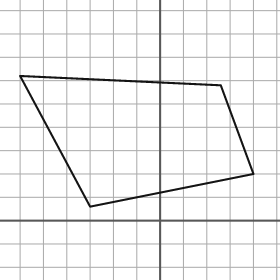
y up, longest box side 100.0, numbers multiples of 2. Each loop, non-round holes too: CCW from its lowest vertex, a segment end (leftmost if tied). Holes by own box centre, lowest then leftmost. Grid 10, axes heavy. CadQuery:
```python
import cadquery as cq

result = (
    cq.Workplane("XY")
    .moveTo(-30.0, 6.0)
    .lineTo(40.0, 20.0)
    .lineTo(26.0, 58.0)
    .lineTo(-60.0, 62.0)
    .close()
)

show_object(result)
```